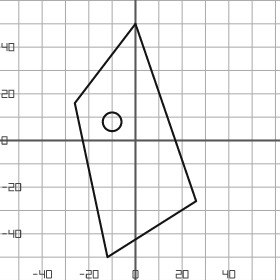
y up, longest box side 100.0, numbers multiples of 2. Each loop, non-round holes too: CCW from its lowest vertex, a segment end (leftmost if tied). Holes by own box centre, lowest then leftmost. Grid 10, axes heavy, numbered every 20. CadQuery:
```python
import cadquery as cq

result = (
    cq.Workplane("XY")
    .moveTo(-12.0, -50.0)
    .lineTo(26.0, -26.0)
    .lineTo(0.0, 50.0)
    .lineTo(-26.0, 16.0)
    .close()
    .moveTo(-10.0, 8.0)
    .circle(4.0)
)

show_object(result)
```